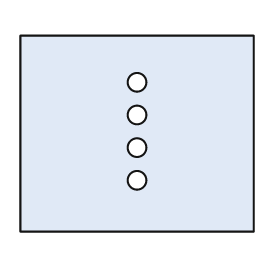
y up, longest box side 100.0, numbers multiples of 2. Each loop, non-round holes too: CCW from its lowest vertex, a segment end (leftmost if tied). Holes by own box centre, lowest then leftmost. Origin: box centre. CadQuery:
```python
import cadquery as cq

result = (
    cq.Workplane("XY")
    .moveTo(-50.0, -42.0)
    .lineTo(50.0, -42.0)
    .lineTo(50.0, 42.0)
    .lineTo(-50.0, 42.0)
    .close()
    .moveTo(0.0, -20.0)
    .circle(4.0)
    .moveTo(0.0, -6.0)
    .circle(4.0)
    .moveTo(0.0, 8.0)
    .circle(4.0)
    .moveTo(0.0, 22.0)
    .circle(4.0)
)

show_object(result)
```